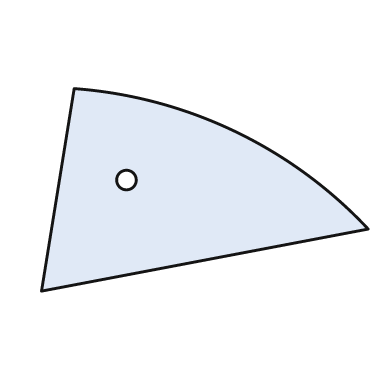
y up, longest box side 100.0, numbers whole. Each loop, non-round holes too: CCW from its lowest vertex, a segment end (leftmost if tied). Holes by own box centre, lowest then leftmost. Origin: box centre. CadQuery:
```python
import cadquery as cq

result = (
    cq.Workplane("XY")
    .moveTo(-50.0, -31.0)
    .lineTo(50.0, -12.0)
    .threePointArc((9.0, 18.0), (-40.0, 31.0))
    .close()
    .moveTo(-24.0, 3.0)
    .circle(3.0)
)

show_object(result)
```